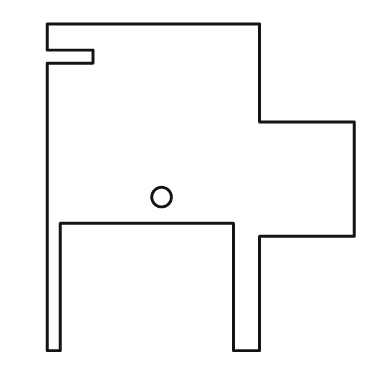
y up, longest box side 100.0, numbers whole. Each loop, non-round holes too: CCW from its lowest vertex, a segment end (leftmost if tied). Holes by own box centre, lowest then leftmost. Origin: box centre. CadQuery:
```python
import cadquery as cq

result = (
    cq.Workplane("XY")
    .moveTo(-47.0, -50.0)
    .lineTo(-43.0, -50.0)
    .lineTo(-43.0, -11.0)
    .lineTo(10.0, -11.0)
    .lineTo(10.0, -50.0)
    .lineTo(18.0, -50.0)
    .lineTo(18.0, -15.0)
    .lineTo(47.0, -15.0)
    .lineTo(47.0, 20.0)
    .lineTo(18.0, 20.0)
    .lineTo(18.0, 50.0)
    .lineTo(-47.0, 50.0)
    .lineTo(-47.0, 42.0)
    .lineTo(-33.0, 42.0)
    .lineTo(-33.0, 38.0)
    .lineTo(-47.0, 38.0)
    .close()
    .moveTo(-12.0, -3.0)
    .circle(3.0)
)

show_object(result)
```